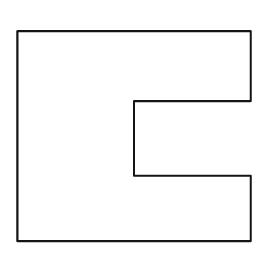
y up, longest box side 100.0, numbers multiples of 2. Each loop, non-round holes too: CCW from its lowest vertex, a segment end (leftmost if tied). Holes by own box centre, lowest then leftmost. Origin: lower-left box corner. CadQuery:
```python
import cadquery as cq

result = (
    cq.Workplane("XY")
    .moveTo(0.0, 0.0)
    .lineTo(100.0, 0.0)
    .lineTo(100.0, 28.0)
    .lineTo(50.0, 28.0)
    .lineTo(50.0, 60.0)
    .lineTo(100.0, 60.0)
    .lineTo(100.0, 90.0)
    .lineTo(0.0, 90.0)
    .close()
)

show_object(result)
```